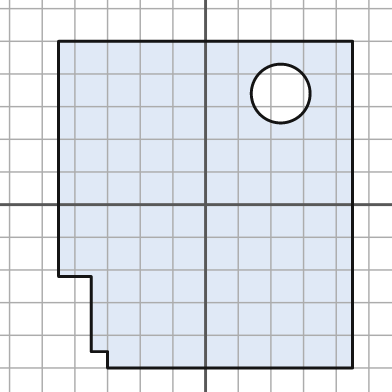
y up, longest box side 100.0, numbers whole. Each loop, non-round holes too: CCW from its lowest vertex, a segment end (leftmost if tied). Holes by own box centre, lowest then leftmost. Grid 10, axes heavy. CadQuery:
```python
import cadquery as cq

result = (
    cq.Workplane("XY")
    .moveTo(-30.0, -50.0)
    .lineTo(45.0, -50.0)
    .lineTo(45.0, 50.0)
    .lineTo(-45.0, 50.0)
    .lineTo(-45.0, -22.0)
    .lineTo(-35.0, -22.0)
    .lineTo(-35.0, -45.0)
    .lineTo(-30.0, -45.0)
    .close()
    .moveTo(23.0, 34.0)
    .circle(9.0)
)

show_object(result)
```